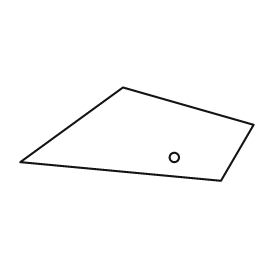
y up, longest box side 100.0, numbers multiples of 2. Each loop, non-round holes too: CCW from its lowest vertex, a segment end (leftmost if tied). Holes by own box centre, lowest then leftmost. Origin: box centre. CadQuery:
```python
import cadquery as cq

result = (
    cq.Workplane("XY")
    .moveTo(36.0, -20.0)
    .lineTo(50.0, 4.0)
    .lineTo(-6.0, 20.0)
    .lineTo(-50.0, -12.0)
    .close()
    .moveTo(16.0, -10.0)
    .circle(2.0)
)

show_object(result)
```